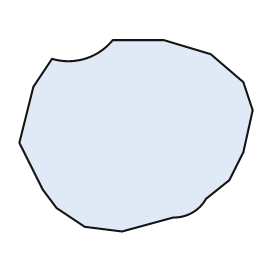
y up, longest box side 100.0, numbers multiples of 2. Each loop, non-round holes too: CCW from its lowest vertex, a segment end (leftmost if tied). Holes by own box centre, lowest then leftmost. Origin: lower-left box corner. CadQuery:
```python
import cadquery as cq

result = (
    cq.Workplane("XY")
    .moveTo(44.0, 0.0)
    .lineTo(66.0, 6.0)
    .threePointArc((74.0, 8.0), (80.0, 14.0))
    .lineTo(90.0, 22.0)
    .lineTo(96.0, 34.0)
    .lineTo(100.0, 52.0)
    .lineTo(96.0, 64.0)
    .lineTo(82.0, 76.0)
    .lineTo(62.0, 82.0)
    .lineTo(40.0, 82.0)
    .threePointArc((28.0, 74.0), (14.0, 74.0))
    .lineTo(6.0, 62.0)
    .lineTo(0.0, 38.0)
    .lineTo(10.0, 18.0)
    .lineTo(16.0, 10.0)
    .lineTo(28.0, 2.0)
    .close()
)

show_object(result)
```